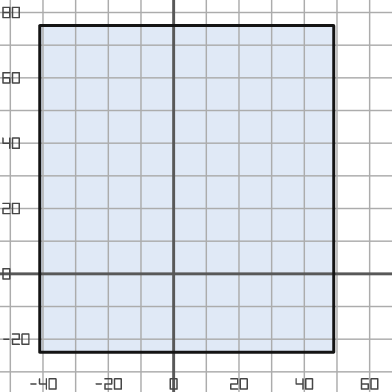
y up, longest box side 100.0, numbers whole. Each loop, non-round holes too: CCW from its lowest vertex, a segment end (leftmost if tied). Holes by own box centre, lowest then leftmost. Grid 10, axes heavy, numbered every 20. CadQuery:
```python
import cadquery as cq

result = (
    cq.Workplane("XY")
    .moveTo(-41.0, -24.0)
    .lineTo(49.0, -24.0)
    .lineTo(49.0, 76.0)
    .lineTo(-41.0, 76.0)
    .close()
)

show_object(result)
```